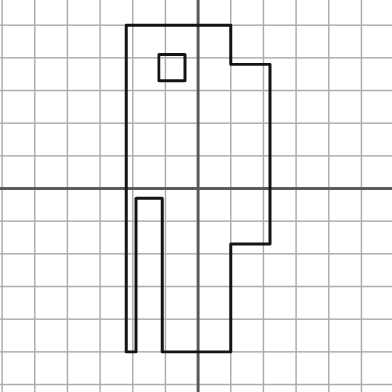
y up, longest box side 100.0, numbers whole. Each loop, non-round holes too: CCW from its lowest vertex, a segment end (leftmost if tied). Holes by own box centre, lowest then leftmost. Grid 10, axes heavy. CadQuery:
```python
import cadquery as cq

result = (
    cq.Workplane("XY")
    .moveTo(-22.0, -50.0)
    .lineTo(-19.0, -50.0)
    .lineTo(-19.0, -3.0)
    .lineTo(-11.0, -3.0)
    .lineTo(-11.0, -50.0)
    .lineTo(10.0, -50.0)
    .lineTo(10.0, -17.0)
    .lineTo(22.0, -17.0)
    .lineTo(22.0, 38.0)
    .lineTo(10.0, 38.0)
    .lineTo(10.0, 50.0)
    .lineTo(-22.0, 50.0)
    .close()
    .moveTo(-12.0, 33.0)
    .lineTo(-4.0, 33.0)
    .lineTo(-4.0, 41.0)
    .lineTo(-12.0, 41.0)
    .close()
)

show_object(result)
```